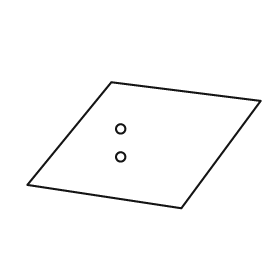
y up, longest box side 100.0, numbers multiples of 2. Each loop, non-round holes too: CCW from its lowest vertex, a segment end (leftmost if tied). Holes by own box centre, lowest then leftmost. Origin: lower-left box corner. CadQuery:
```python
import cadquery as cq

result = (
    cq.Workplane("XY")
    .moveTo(66.0, 0.0)
    .lineTo(100.0, 46.0)
    .lineTo(36.0, 54.0)
    .lineTo(0.0, 10.0)
    .close()
    .moveTo(40.0, 22.0)
    .circle(2.0)
    .moveTo(40.0, 34.0)
    .circle(2.0)
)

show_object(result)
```